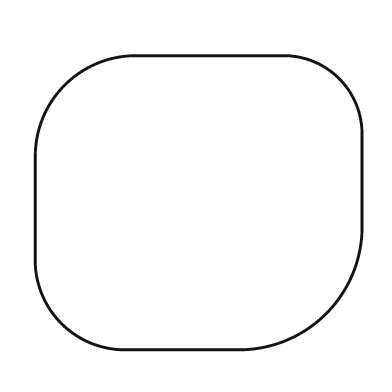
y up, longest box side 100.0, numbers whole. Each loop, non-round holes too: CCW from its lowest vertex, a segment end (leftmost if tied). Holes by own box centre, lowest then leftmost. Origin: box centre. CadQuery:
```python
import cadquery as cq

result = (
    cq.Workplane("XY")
    .moveTo(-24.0, -45.0)
    .lineTo(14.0, -45.0)
    .threePointArc((39.0, -34.0), (50.0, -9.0))
    .lineTo(50.0, 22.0)
    .threePointArc((43.0, 38.0), (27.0, 45.0))
    .lineTo(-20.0, 45.0)
    .threePointArc((-41.0, 36.0), (-50.0, 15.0))
    .lineTo(-50.0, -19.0)
    .threePointArc((-42.0, -37.0), (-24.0, -45.0))
    .close()
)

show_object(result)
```